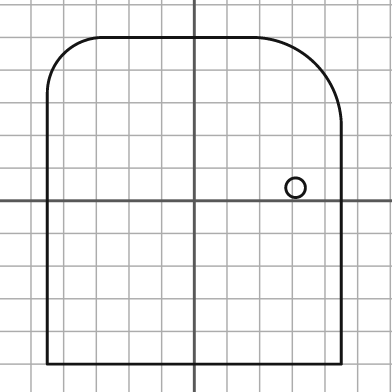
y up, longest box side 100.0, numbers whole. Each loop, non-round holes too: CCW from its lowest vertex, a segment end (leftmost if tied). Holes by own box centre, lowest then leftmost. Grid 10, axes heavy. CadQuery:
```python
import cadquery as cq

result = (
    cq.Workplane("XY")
    .moveTo(-45.0, -50.0)
    .lineTo(45.0, -50.0)
    .lineTo(45.0, 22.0)
    .threePointArc((37.0, 42.0), (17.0, 50.0))
    .lineTo(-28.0, 50.0)
    .threePointArc((-40.0, 45.0), (-45.0, 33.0))
    .close()
    .moveTo(31.0, 4.0)
    .circle(3.0)
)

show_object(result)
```